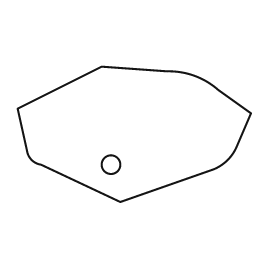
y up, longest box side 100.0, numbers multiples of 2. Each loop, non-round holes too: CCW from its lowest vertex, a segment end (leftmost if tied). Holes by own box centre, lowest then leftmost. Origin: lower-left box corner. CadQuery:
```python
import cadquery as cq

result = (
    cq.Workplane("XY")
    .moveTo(44.0, 0.0)
    .lineTo(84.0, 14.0)
    .threePointArc((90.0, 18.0), (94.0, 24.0))
    .lineTo(100.0, 38.0)
    .lineTo(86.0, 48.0)
    .threePointArc((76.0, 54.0), (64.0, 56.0))
    .lineTo(36.0, 58.0)
    .lineTo(0.0, 40.0)
    .lineTo(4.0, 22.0)
    .threePointArc((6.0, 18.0), (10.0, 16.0))
    .close()
    .moveTo(40.0, 16.0)
    .circle(4.0)
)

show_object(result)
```